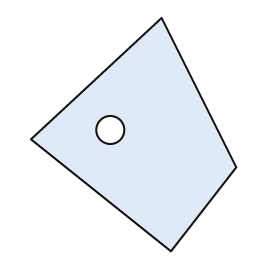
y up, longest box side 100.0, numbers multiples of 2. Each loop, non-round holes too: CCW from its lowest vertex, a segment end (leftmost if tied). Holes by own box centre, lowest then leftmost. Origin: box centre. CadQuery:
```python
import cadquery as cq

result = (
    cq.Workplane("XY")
    .moveTo(16.0, -50.0)
    .lineTo(44.0, -14.0)
    .lineTo(12.0, 50.0)
    .lineTo(-44.0, -2.0)
    .close()
    .moveTo(-10.0, 2.0)
    .circle(6.0)
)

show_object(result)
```